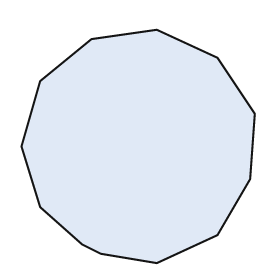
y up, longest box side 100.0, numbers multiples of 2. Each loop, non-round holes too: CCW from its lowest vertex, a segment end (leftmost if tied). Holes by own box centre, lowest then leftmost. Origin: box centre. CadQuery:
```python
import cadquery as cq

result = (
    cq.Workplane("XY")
    .moveTo(8.0, -50.0)
    .lineTo(34.0, -38.0)
    .lineTo(48.0, -14.0)
    .lineTo(50.0, 14.0)
    .lineTo(34.0, 38.0)
    .lineTo(8.0, 50.0)
    .lineTo(-20.0, 46.0)
    .lineTo(-42.0, 28.0)
    .lineTo(-50.0, 0.0)
    .lineTo(-42.0, -26.0)
    .lineTo(-24.0, -42.0)
    .lineTo(-16.0, -46.0)
    .close()
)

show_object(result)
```